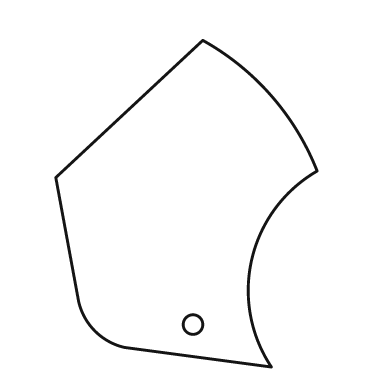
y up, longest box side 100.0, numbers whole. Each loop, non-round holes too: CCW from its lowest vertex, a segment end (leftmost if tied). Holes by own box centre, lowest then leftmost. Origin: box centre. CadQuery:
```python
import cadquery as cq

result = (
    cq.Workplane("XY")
    .moveTo(26.0, -50.0)
    .threePointArc((20.0, -17.0), (40.0, 10.0))
    .threePointArc((26.0, 33.0), (5.0, 50.0))
    .lineTo(-40.0, 8.0)
    .lineTo(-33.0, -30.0)
    .threePointArc((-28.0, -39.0), (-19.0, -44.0))
    .close()
    .moveTo(2.0, -37.0)
    .circle(3.0)
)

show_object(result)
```